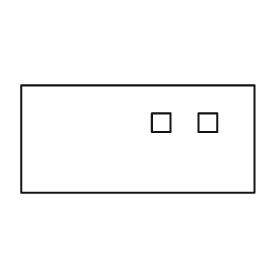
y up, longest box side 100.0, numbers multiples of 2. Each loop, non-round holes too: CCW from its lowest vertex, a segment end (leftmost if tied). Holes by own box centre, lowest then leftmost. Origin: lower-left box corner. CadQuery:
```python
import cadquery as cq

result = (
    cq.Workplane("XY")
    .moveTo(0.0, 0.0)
    .lineTo(100.0, 0.0)
    .lineTo(100.0, 46.0)
    .lineTo(0.0, 46.0)
    .close()
    .moveTo(56.0, 26.0)
    .lineTo(64.0, 26.0)
    .lineTo(64.0, 34.0)
    .lineTo(56.0, 34.0)
    .close()
    .moveTo(76.0, 26.0)
    .lineTo(84.0, 26.0)
    .lineTo(84.0, 34.0)
    .lineTo(76.0, 34.0)
    .close()
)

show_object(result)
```